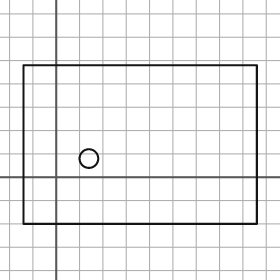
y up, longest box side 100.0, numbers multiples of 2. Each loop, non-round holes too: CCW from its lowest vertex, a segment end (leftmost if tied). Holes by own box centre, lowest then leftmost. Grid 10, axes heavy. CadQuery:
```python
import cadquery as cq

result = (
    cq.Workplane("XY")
    .moveTo(-14.0, -20.0)
    .lineTo(86.0, -20.0)
    .lineTo(86.0, 48.0)
    .lineTo(-14.0, 48.0)
    .close()
    .moveTo(14.0, 8.0)
    .circle(4.0)
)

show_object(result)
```